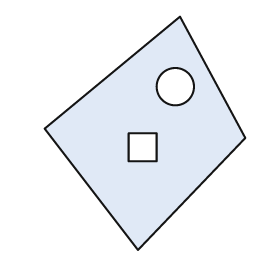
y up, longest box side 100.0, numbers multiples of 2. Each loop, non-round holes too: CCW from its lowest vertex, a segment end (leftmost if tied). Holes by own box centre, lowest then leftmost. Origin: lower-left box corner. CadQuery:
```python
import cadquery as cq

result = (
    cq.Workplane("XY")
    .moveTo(40.0, 0.0)
    .lineTo(86.0, 48.0)
    .lineTo(58.0, 100.0)
    .lineTo(0.0, 52.0)
    .close()
    .moveTo(36.0, 38.0)
    .lineTo(48.0, 38.0)
    .lineTo(48.0, 50.0)
    .lineTo(36.0, 50.0)
    .close()
    .moveTo(56.0, 70.0)
    .circle(8.0)
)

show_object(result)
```